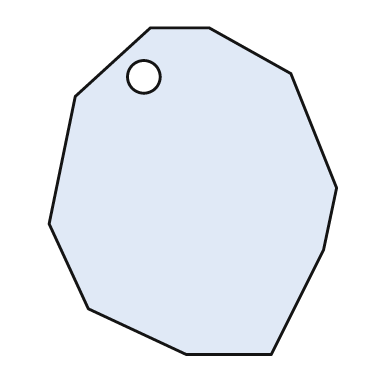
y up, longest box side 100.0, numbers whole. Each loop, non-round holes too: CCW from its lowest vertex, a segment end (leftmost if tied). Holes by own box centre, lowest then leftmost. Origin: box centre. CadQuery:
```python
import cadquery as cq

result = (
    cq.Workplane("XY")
    .moveTo(-2.0, -50.0)
    .lineTo(24.0, -50.0)
    .lineTo(40.0, -18.0)
    .lineTo(44.0, 1.0)
    .lineTo(30.0, 36.0)
    .lineTo(5.0, 50.0)
    .lineTo(-13.0, 50.0)
    .lineTo(-36.0, 29.0)
    .lineTo(-44.0, -10.0)
    .lineTo(-32.0, -36.0)
    .close()
    .moveTo(-15.0, 35.0)
    .circle(5.0)
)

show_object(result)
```